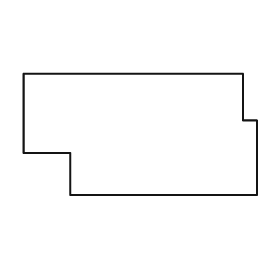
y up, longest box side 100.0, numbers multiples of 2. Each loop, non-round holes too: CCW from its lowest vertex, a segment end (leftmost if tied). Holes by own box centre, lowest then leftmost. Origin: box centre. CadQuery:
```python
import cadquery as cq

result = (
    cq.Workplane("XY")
    .moveTo(-30.0, -26.0)
    .lineTo(50.0, -26.0)
    .lineTo(50.0, 6.0)
    .lineTo(44.0, 6.0)
    .lineTo(44.0, 26.0)
    .lineTo(-50.0, 26.0)
    .lineTo(-50.0, -8.0)
    .lineTo(-30.0, -8.0)
    .close()
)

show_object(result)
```